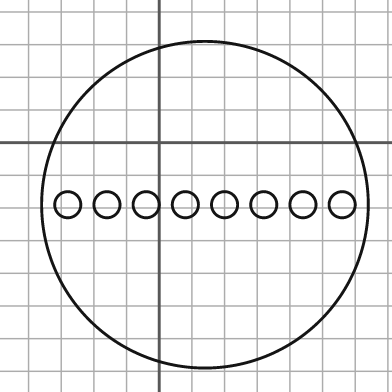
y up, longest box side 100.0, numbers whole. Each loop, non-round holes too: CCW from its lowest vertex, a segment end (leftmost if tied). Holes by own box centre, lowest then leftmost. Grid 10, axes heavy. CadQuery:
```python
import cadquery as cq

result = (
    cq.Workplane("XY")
    .moveTo(14.0, -19.0)
    .circle(50.0)
    .moveTo(-28.0, -19.0)
    .circle(4.0)
    .moveTo(-16.0, -19.0)
    .circle(4.0)
    .moveTo(-4.0, -19.0)
    .circle(4.0)
    .moveTo(8.0, -19.0)
    .circle(4.0)
    .moveTo(20.0, -19.0)
    .circle(4.0)
    .moveTo(32.0, -19.0)
    .circle(4.0)
    .moveTo(44.0, -19.0)
    .circle(4.0)
    .moveTo(56.0, -19.0)
    .circle(4.0)
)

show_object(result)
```